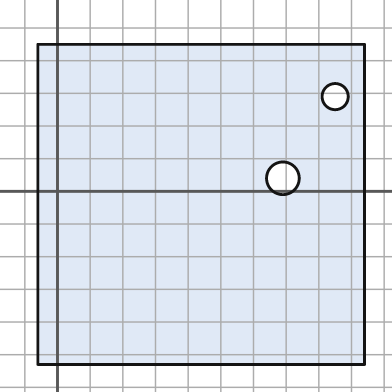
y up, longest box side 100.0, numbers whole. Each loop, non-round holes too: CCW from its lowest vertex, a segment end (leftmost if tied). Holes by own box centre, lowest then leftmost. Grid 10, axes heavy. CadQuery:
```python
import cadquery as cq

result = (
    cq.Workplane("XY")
    .moveTo(-6.0, -53.0)
    .lineTo(94.0, -53.0)
    .lineTo(94.0, 45.0)
    .lineTo(-6.0, 45.0)
    .close()
    .moveTo(69.0, 4.0)
    .circle(5.0)
    .moveTo(85.0, 29.0)
    .circle(4.0)
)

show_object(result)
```